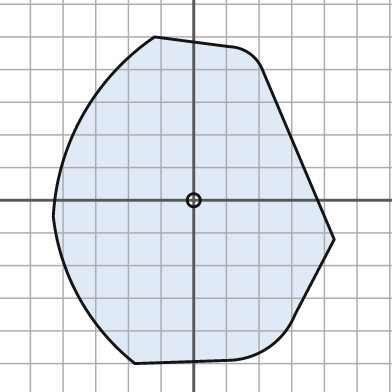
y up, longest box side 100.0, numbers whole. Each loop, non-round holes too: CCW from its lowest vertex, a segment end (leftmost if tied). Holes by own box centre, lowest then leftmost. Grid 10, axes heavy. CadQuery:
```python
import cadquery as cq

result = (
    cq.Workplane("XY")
    .moveTo(-18.0, -50.0)
    .lineTo(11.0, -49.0)
    .threePointArc((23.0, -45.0), (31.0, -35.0))
    .lineTo(43.0, -12.0)
    .lineTo(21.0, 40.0)
    .threePointArc((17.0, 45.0), (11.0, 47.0))
    .lineTo(-12.0, 50.0)
    .threePointArc((-34.0, 26.0), (-43.0, -5.0))
    .threePointArc((-35.0, -30.0), (-18.0, -50.0))
    .close()
    .moveTo(0.0, 0.0)
    .circle(2.0)
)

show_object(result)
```